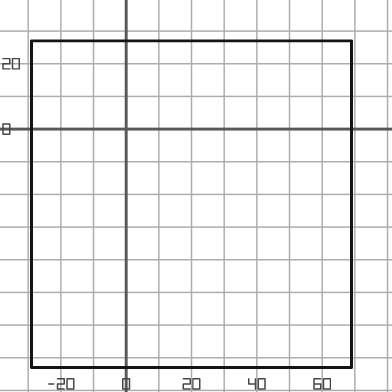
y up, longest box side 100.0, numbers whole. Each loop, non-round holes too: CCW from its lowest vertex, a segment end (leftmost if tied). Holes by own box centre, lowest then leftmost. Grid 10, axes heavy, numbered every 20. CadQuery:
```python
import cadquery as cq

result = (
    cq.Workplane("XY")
    .moveTo(-29.0, -73.0)
    .lineTo(69.0, -73.0)
    .lineTo(69.0, 27.0)
    .lineTo(-29.0, 27.0)
    .close()
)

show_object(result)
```